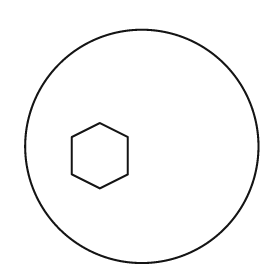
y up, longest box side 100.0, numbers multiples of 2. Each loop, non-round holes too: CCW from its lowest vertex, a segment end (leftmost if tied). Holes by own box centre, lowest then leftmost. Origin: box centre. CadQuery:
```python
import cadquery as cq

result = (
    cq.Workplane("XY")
    .moveTo(0.0, 0.0)
    .circle(50.0)
    .moveTo(-18.0, -18.0)
    .lineTo(-6.0, -12.0)
    .lineTo(-6.0, 4.0)
    .lineTo(-18.0, 10.0)
    .lineTo(-30.0, 4.0)
    .lineTo(-30.0, -12.0)
    .close()
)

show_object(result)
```